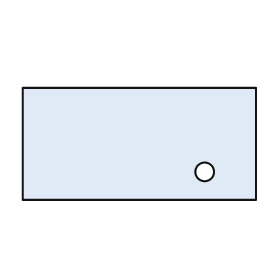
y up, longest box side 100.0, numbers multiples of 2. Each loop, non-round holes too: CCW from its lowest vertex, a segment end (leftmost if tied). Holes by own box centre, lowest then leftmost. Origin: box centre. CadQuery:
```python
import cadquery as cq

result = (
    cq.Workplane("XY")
    .moveTo(-50.0, -24.0)
    .lineTo(50.0, -24.0)
    .lineTo(50.0, 24.0)
    .lineTo(-50.0, 24.0)
    .close()
    .moveTo(28.0, -12.0)
    .circle(4.0)
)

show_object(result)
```